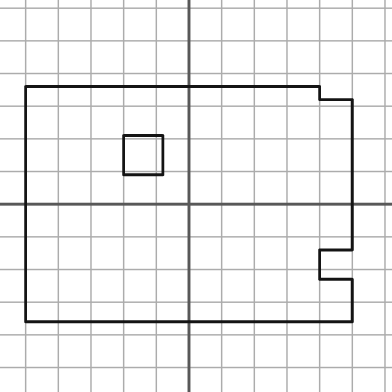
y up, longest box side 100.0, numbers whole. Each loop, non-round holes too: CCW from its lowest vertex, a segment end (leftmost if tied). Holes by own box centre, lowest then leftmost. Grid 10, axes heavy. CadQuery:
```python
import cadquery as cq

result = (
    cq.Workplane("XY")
    .moveTo(-50.0, -36.0)
    .lineTo(50.0, -36.0)
    .lineTo(50.0, -23.0)
    .lineTo(40.0, -23.0)
    .lineTo(40.0, -14.0)
    .lineTo(50.0, -14.0)
    .lineTo(50.0, 32.0)
    .lineTo(40.0, 32.0)
    .lineTo(40.0, 36.0)
    .lineTo(-50.0, 36.0)
    .close()
    .moveTo(-20.0, 9.0)
    .lineTo(-8.0, 9.0)
    .lineTo(-8.0, 21.0)
    .lineTo(-20.0, 21.0)
    .close()
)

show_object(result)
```